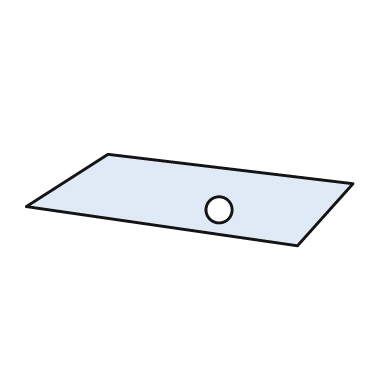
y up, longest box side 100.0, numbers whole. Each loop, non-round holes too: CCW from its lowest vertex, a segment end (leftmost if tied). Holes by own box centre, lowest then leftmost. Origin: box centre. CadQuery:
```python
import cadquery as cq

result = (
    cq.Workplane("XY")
    .moveTo(33.0, -14.0)
    .lineTo(50.0, 5.0)
    .lineTo(-25.0, 14.0)
    .lineTo(-50.0, -2.0)
    .close()
    .moveTo(9.0, -3.0)
    .circle(4.0)
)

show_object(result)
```